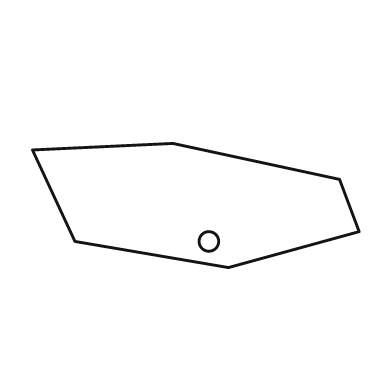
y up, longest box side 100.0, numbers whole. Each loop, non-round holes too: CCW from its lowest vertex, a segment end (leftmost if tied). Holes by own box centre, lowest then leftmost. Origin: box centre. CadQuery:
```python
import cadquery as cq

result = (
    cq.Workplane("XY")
    .moveTo(10.0, -19.0)
    .lineTo(50.0, -8.0)
    .lineTo(44.0, 8.0)
    .lineTo(-7.0, 19.0)
    .lineTo(-50.0, 17.0)
    .lineTo(-37.0, -11.0)
    .close()
    .moveTo(4.0, -11.0)
    .circle(3.0)
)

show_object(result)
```